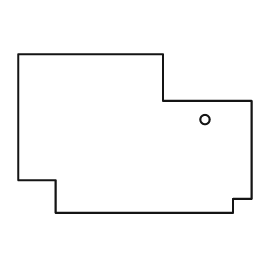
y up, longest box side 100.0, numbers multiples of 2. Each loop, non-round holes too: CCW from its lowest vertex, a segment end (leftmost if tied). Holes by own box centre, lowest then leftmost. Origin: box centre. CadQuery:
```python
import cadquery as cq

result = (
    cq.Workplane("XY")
    .moveTo(-34.0, -34.0)
    .lineTo(42.0, -34.0)
    .lineTo(42.0, -28.0)
    .lineTo(50.0, -28.0)
    .lineTo(50.0, 14.0)
    .lineTo(12.0, 14.0)
    .lineTo(12.0, 34.0)
    .lineTo(-50.0, 34.0)
    .lineTo(-50.0, -20.0)
    .lineTo(-34.0, -20.0)
    .close()
    .moveTo(30.0, 6.0)
    .circle(2.0)
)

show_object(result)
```